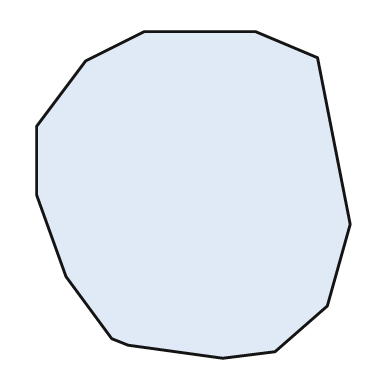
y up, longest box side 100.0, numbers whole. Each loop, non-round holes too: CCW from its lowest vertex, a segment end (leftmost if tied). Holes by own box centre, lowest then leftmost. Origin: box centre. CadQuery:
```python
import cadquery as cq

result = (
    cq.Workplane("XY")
    .moveTo(9.0, -50.0)
    .lineTo(25.0, -48.0)
    .lineTo(41.0, -34.0)
    .lineTo(48.0, -9.0)
    .lineTo(38.0, 42.0)
    .lineTo(19.0, 50.0)
    .lineTo(-15.0, 50.0)
    .lineTo(-33.0, 41.0)
    .lineTo(-48.0, 21.0)
    .lineTo(-48.0, 0.0)
    .lineTo(-39.0, -25.0)
    .lineTo(-25.0, -44.0)
    .lineTo(-20.0, -46.0)
    .close()
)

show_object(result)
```